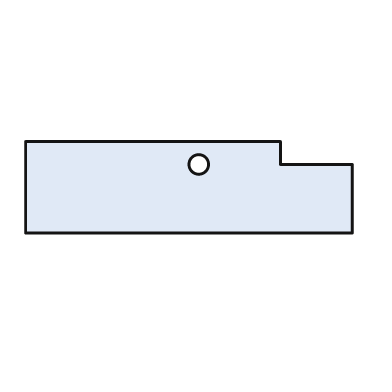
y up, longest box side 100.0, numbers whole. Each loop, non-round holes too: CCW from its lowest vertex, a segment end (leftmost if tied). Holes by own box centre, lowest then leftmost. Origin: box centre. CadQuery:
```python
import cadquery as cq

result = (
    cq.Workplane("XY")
    .moveTo(-50.0, -14.0)
    .lineTo(50.0, -14.0)
    .lineTo(50.0, 7.0)
    .lineTo(28.0, 7.0)
    .lineTo(28.0, 14.0)
    .lineTo(-50.0, 14.0)
    .close()
    .moveTo(3.0, 7.0)
    .circle(3.0)
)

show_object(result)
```